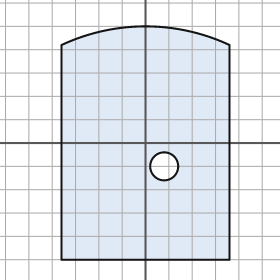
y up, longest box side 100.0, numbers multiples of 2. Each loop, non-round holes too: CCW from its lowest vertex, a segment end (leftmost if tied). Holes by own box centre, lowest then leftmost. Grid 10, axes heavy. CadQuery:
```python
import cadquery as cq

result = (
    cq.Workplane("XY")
    .moveTo(-36.0, -50.0)
    .lineTo(36.0, -50.0)
    .lineTo(36.0, 42.0)
    .threePointArc((0.0, 50.0), (-36.0, 42.0))
    .close()
    .moveTo(8.0, -10.0)
    .circle(6.0)
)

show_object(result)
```